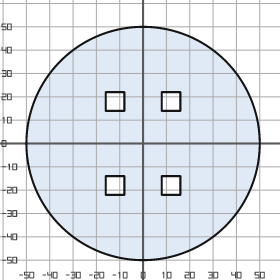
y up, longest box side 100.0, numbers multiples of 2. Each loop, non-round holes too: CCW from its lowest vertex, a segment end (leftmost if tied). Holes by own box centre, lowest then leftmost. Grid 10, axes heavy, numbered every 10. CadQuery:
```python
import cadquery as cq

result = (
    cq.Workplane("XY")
    .moveTo(0.0, 0.0)
    .circle(50.0)
    .moveTo(-16.0, -22.0)
    .lineTo(-8.0, -22.0)
    .lineTo(-8.0, -14.0)
    .lineTo(-16.0, -14.0)
    .close()
    .moveTo(8.0, -22.0)
    .lineTo(16.0, -22.0)
    .lineTo(16.0, -14.0)
    .lineTo(8.0, -14.0)
    .close()
    .moveTo(-16.0, 14.0)
    .lineTo(-8.0, 14.0)
    .lineTo(-8.0, 22.0)
    .lineTo(-16.0, 22.0)
    .close()
    .moveTo(8.0, 14.0)
    .lineTo(16.0, 14.0)
    .lineTo(16.0, 22.0)
    .lineTo(8.0, 22.0)
    .close()
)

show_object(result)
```